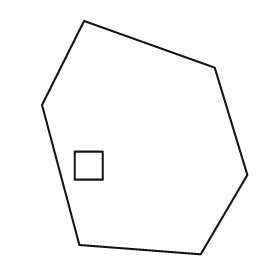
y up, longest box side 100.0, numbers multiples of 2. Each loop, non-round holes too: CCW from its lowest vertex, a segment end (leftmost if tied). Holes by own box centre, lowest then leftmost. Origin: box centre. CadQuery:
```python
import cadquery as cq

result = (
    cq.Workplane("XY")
    .moveTo(24.0, -50.0)
    .lineTo(44.0, -16.0)
    .lineTo(30.0, 30.0)
    .lineTo(-26.0, 50.0)
    .lineTo(-44.0, 14.0)
    .lineTo(-28.0, -46.0)
    .close()
    .moveTo(-30.0, -18.0)
    .lineTo(-18.0, -18.0)
    .lineTo(-18.0, -6.0)
    .lineTo(-30.0, -6.0)
    .close()
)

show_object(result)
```